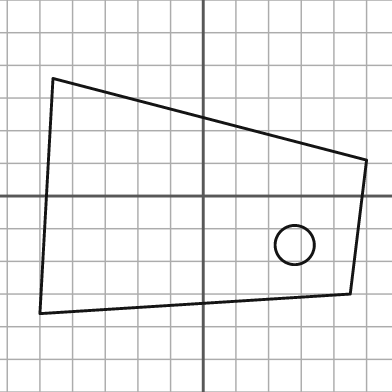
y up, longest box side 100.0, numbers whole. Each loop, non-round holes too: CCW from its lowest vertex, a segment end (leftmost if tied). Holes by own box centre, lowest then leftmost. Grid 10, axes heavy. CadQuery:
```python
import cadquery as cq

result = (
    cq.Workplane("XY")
    .moveTo(-50.0, -36.0)
    .lineTo(45.0, -30.0)
    .lineTo(50.0, 11.0)
    .lineTo(-46.0, 36.0)
    .close()
    .moveTo(28.0, -15.0)
    .circle(6.0)
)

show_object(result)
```